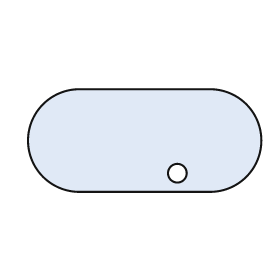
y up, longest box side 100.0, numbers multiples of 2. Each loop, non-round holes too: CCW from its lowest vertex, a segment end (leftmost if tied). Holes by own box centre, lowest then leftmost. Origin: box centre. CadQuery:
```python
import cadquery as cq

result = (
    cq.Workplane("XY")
    .moveTo(-28.0, -22.0)
    .lineTo(28.0, -22.0)
    .threePointArc((50.0, 0.0), (28.0, 22.0))
    .lineTo(-28.0, 22.0)
    .threePointArc((-50.0, 0.0), (-28.0, -22.0))
    .close()
    .moveTo(14.0, -14.0)
    .circle(4.0)
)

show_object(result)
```